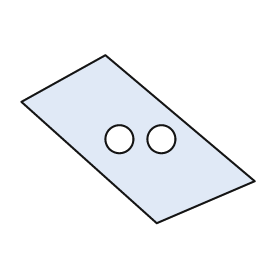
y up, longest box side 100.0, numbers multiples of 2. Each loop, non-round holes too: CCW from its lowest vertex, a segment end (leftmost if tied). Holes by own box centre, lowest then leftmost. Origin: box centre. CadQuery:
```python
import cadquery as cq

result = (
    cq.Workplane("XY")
    .moveTo(8.0, -36.0)
    .lineTo(50.0, -18.0)
    .lineTo(-14.0, 36.0)
    .lineTo(-50.0, 16.0)
    .close()
    .moveTo(-8.0, 0.0)
    .circle(6.0)
    .moveTo(10.0, 0.0)
    .circle(6.0)
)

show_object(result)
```